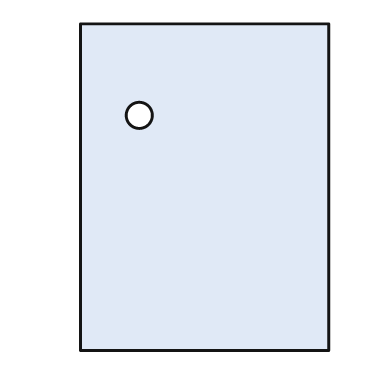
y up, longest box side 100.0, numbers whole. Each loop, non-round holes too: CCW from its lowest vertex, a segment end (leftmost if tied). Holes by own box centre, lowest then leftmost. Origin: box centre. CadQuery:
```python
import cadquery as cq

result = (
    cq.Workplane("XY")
    .moveTo(-38.0, -50.0)
    .lineTo(38.0, -50.0)
    .lineTo(38.0, 50.0)
    .lineTo(-38.0, 50.0)
    .close()
    .moveTo(-20.0, 22.0)
    .circle(4.0)
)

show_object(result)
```